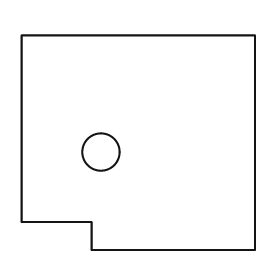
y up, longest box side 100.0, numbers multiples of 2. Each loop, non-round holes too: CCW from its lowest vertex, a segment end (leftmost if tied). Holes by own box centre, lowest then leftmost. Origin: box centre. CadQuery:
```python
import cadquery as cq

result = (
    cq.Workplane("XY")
    .moveTo(-20.0, -46.0)
    .lineTo(50.0, -46.0)
    .lineTo(50.0, 46.0)
    .lineTo(-50.0, 46.0)
    .lineTo(-50.0, -34.0)
    .lineTo(-20.0, -34.0)
    .close()
    .moveTo(-16.0, -4.0)
    .circle(8.0)
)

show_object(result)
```